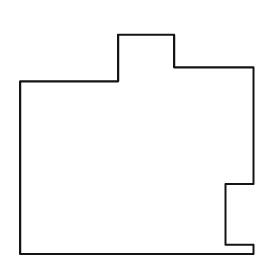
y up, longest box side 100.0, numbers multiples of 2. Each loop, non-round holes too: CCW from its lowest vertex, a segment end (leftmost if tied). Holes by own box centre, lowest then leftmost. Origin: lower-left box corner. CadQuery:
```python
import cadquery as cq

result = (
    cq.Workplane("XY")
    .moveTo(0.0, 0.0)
    .lineTo(100.0, 0.0)
    .lineTo(100.0, 4.0)
    .lineTo(88.0, 4.0)
    .lineTo(88.0, 30.0)
    .lineTo(100.0, 30.0)
    .lineTo(100.0, 80.0)
    .lineTo(66.0, 80.0)
    .lineTo(66.0, 94.0)
    .lineTo(42.0, 94.0)
    .lineTo(42.0, 74.0)
    .lineTo(0.0, 74.0)
    .close()
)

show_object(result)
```